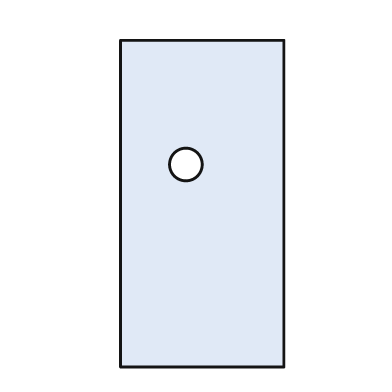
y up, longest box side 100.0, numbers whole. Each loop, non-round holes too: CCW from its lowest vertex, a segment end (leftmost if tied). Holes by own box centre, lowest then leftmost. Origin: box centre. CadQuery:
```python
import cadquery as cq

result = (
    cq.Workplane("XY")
    .moveTo(-25.0, -50.0)
    .lineTo(25.0, -50.0)
    .lineTo(25.0, 50.0)
    .lineTo(-25.0, 50.0)
    .close()
    .moveTo(-5.0, 12.0)
    .circle(5.0)
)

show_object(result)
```